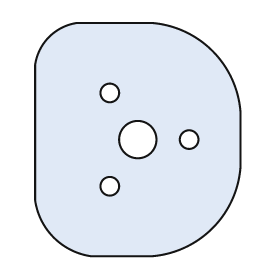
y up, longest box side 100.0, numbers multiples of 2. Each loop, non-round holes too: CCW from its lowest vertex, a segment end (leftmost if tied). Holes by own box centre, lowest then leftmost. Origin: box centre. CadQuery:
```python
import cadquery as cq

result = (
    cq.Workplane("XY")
    .moveTo(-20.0, -50.0)
    .lineTo(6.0, -50.0)
    .threePointArc((32.0, -38.0), (44.0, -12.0))
    .lineTo(44.0, 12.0)
    .threePointArc((32.0, 38.0), (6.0, 50.0))
    .lineTo(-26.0, 50.0)
    .threePointArc((-38.0, 44.0), (-44.0, 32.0))
    .lineTo(-44.0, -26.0)
    .threePointArc((-36.0, -42.0), (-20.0, -50.0))
    .close()
    .moveTo(-12.0, -20.0)
    .circle(4.0)
    .moveTo(0.0, 0.0)
    .circle(8.0)
    .moveTo(22.0, 0.0)
    .circle(4.0)
    .moveTo(-12.0, 20.0)
    .circle(4.0)
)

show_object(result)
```